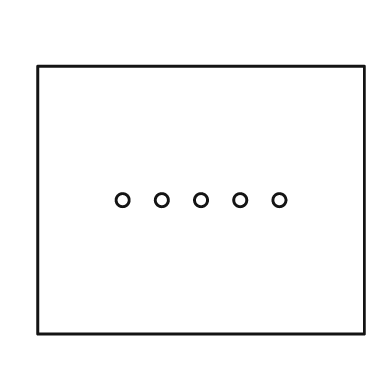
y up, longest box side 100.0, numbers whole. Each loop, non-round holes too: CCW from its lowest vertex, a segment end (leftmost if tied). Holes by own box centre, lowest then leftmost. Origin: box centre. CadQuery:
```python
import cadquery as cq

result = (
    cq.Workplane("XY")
    .moveTo(-50.0, -41.0)
    .lineTo(50.0, -41.0)
    .lineTo(50.0, 41.0)
    .lineTo(-50.0, 41.0)
    .close()
    .moveTo(-24.0, 0.0)
    .circle(2.0)
    .moveTo(-12.0, 0.0)
    .circle(2.0)
    .moveTo(0.0, 0.0)
    .circle(2.0)
    .moveTo(12.0, 0.0)
    .circle(2.0)
    .moveTo(24.0, 0.0)
    .circle(2.0)
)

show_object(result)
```